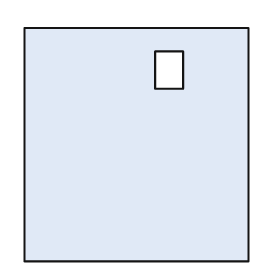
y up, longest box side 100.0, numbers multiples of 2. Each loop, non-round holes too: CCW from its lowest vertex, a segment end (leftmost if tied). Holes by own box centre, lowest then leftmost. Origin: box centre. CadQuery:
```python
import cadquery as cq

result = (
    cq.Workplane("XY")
    .moveTo(-48.0, -50.0)
    .lineTo(48.0, -50.0)
    .lineTo(48.0, 50.0)
    .lineTo(-48.0, 50.0)
    .close()
    .moveTo(8.0, 24.0)
    .lineTo(20.0, 24.0)
    .lineTo(20.0, 40.0)
    .lineTo(8.0, 40.0)
    .close()
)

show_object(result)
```